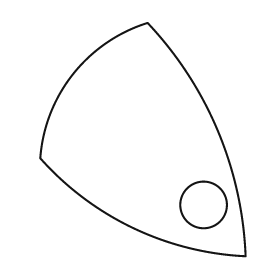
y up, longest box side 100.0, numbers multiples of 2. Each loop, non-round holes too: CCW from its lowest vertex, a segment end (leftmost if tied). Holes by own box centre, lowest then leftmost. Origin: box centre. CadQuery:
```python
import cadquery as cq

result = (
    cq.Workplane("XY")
    .moveTo(44.0, -50.0)
    .threePointArc((32.0, 4.0), (2.0, 50.0))
    .threePointArc((-30.0, 28.0), (-44.0, -8.0))
    .threePointArc((-4.0, -38.0), (44.0, -50.0))
    .close()
    .moveTo(26.0, -28.0)
    .circle(10.0)
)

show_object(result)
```